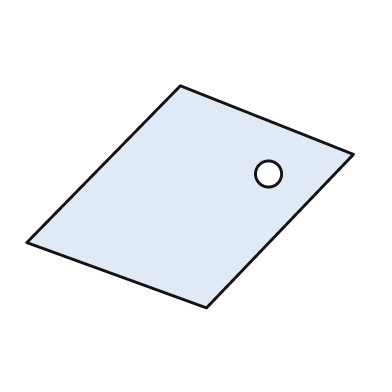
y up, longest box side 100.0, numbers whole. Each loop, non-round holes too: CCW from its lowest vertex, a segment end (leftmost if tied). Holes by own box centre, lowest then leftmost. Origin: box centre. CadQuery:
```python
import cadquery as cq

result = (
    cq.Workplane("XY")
    .moveTo(5.0, -34.0)
    .lineTo(50.0, 13.0)
    .lineTo(-3.0, 34.0)
    .lineTo(-50.0, -14.0)
    .close()
    .moveTo(24.0, 7.0)
    .circle(4.0)
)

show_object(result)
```